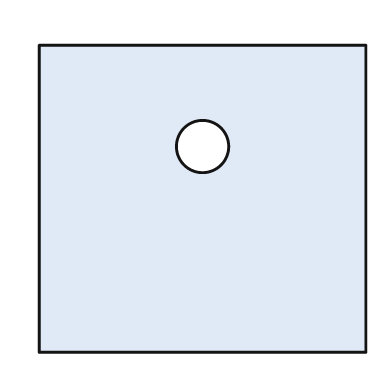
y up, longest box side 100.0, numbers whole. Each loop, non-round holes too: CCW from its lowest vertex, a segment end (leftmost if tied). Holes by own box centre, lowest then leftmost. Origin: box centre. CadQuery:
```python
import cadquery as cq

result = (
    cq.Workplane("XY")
    .moveTo(-50.0, -47.0)
    .lineTo(50.0, -47.0)
    .lineTo(50.0, 47.0)
    .lineTo(-50.0, 47.0)
    .close()
    .moveTo(0.0, 16.0)
    .circle(8.0)
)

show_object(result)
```